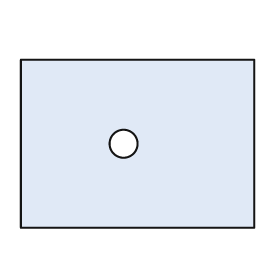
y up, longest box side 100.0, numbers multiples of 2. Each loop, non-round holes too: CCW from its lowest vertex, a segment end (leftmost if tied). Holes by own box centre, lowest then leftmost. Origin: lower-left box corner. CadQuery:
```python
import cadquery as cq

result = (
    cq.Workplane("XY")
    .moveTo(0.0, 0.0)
    .lineTo(100.0, 0.0)
    .lineTo(100.0, 72.0)
    .lineTo(0.0, 72.0)
    .close()
    .moveTo(44.0, 36.0)
    .circle(6.0)
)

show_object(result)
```